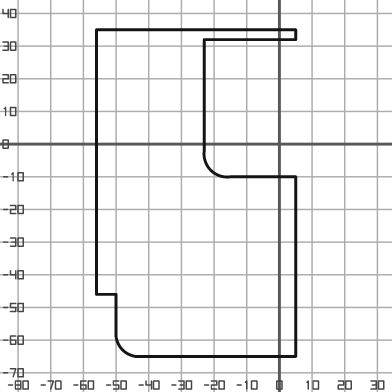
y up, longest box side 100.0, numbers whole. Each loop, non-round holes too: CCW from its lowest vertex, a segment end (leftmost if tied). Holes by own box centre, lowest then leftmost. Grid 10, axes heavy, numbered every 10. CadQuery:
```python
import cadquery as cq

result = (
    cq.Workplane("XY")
    .moveTo(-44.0, -65.0)
    .lineTo(5.0, -65.0)
    .lineTo(5.0, -10.0)
    .lineTo(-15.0, -10.0)
    .threePointArc((-21.0, -8.0), (-23.0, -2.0))
    .lineTo(-23.0, 32.0)
    .lineTo(5.0, 32.0)
    .lineTo(5.0, 35.0)
    .lineTo(-56.0, 35.0)
    .lineTo(-56.0, -46.0)
    .lineTo(-50.0, -46.0)
    .lineTo(-50.0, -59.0)
    .threePointArc((-48.0, -63.0), (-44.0, -65.0))
    .close()
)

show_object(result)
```